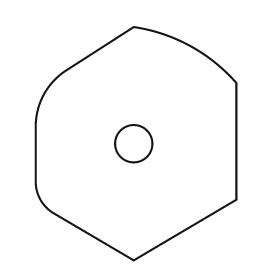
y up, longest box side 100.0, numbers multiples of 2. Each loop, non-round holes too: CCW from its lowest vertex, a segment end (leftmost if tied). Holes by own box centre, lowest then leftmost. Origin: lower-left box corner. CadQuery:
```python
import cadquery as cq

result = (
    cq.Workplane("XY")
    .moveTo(42.0, 0.0)
    .lineTo(86.0, 26.0)
    .lineTo(86.0, 76.0)
    .threePointArc((66.0, 92.0), (42.0, 100.0))
    .lineTo(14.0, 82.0)
    .threePointArc((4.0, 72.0), (0.0, 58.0))
    .lineTo(0.0, 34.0)
    .threePointArc((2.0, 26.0), (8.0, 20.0))
    .close()
    .moveTo(42.0, 50.0)
    .circle(8.0)
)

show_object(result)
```